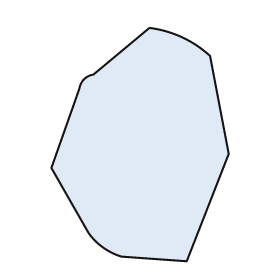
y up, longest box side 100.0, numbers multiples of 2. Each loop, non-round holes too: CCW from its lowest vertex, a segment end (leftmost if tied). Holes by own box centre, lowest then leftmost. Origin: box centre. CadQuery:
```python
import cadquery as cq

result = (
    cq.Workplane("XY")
    .moveTo(20.0, -50.0)
    .lineTo(38.0, -4.0)
    .lineTo(30.0, 38.0)
    .threePointArc((18.0, 46.0), (4.0, 50.0))
    .lineTo(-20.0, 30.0)
    .threePointArc((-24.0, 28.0), (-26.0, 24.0))
    .lineTo(-38.0, -10.0)
    .lineTo(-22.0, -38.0)
    .threePointArc((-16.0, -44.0), (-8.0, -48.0))
    .close()
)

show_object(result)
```